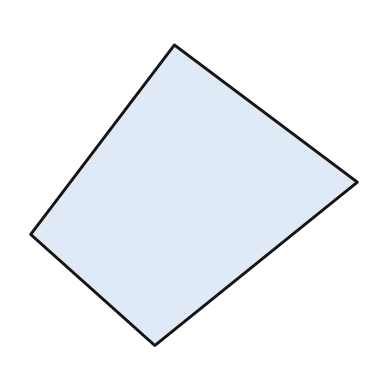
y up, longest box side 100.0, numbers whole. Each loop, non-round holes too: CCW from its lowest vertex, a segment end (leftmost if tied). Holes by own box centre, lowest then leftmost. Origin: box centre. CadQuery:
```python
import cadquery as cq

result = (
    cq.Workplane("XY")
    .moveTo(-12.0, -46.0)
    .lineTo(50.0, 4.0)
    .lineTo(-6.0, 46.0)
    .lineTo(-50.0, -12.0)
    .close()
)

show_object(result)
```